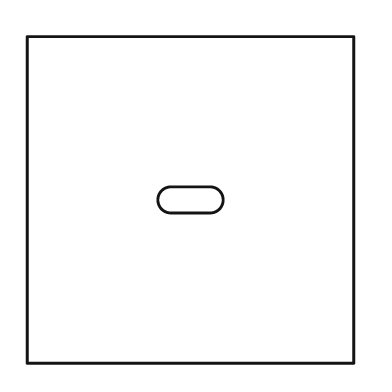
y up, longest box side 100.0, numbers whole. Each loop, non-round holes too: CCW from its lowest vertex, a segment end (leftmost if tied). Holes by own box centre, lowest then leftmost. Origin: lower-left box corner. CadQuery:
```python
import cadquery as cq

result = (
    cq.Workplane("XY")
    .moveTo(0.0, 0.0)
    .lineTo(100.0, 0.0)
    .lineTo(100.0, 100.0)
    .lineTo(0.0, 100.0)
    .close()
    .moveTo(44.0, 46.0)
    .lineTo(56.0, 46.0)
    .threePointArc((60.0, 50.0), (56.0, 54.0))
    .lineTo(44.0, 54.0)
    .threePointArc((40.0, 50.0), (44.0, 46.0))
    .close()
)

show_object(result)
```